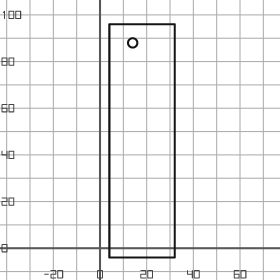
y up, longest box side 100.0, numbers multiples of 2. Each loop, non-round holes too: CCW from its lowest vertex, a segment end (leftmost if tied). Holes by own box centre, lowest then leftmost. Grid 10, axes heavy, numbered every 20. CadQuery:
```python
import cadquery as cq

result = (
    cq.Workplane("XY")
    .moveTo(4.0, -4.0)
    .lineTo(32.0, -4.0)
    .lineTo(32.0, 96.0)
    .lineTo(4.0, 96.0)
    .close()
    .moveTo(14.0, 88.0)
    .circle(2.0)
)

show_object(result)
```